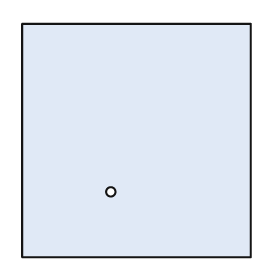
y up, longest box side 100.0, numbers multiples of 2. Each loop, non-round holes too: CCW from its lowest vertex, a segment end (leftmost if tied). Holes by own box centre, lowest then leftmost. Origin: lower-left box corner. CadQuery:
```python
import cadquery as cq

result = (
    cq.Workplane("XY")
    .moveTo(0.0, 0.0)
    .lineTo(98.0, 0.0)
    .lineTo(98.0, 100.0)
    .lineTo(0.0, 100.0)
    .close()
    .moveTo(38.0, 28.0)
    .circle(2.0)
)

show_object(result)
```